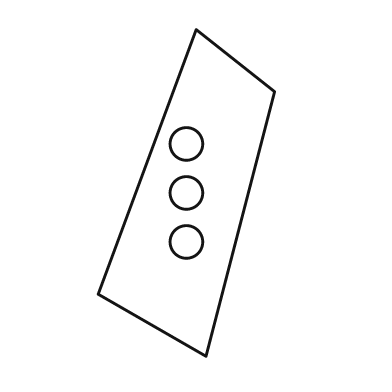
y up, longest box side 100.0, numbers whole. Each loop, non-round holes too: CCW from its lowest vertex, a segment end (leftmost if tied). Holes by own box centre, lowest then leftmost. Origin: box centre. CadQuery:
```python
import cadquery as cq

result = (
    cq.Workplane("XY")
    .moveTo(6.0, -50.0)
    .lineTo(27.0, 31.0)
    .lineTo(3.0, 50.0)
    .lineTo(-27.0, -31.0)
    .close()
    .moveTo(0.0, -15.0)
    .circle(5.0)
    .moveTo(0.0, 0.0)
    .circle(5.0)
    .moveTo(0.0, 15.0)
    .circle(5.0)
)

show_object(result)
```